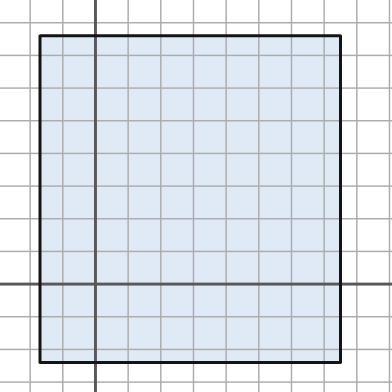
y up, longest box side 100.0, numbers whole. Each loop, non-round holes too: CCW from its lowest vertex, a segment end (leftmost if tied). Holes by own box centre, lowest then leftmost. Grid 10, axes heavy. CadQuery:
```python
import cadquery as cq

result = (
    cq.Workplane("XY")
    .moveTo(-17.0, -24.0)
    .lineTo(75.0, -24.0)
    .lineTo(75.0, 76.0)
    .lineTo(-17.0, 76.0)
    .close()
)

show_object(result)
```